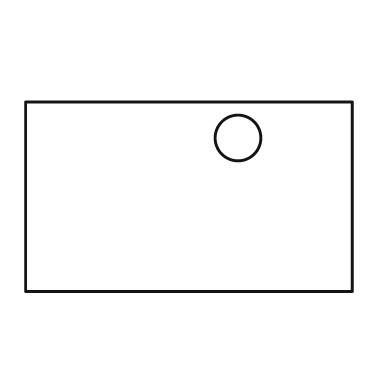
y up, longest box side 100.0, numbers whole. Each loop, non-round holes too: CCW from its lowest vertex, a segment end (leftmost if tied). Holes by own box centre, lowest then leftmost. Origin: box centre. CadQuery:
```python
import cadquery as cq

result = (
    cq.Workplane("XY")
    .moveTo(-50.0, -29.0)
    .lineTo(50.0, -29.0)
    .lineTo(50.0, 29.0)
    .lineTo(-50.0, 29.0)
    .close()
    .moveTo(15.0, 18.0)
    .circle(7.0)
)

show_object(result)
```